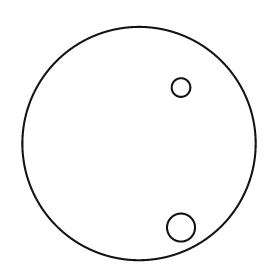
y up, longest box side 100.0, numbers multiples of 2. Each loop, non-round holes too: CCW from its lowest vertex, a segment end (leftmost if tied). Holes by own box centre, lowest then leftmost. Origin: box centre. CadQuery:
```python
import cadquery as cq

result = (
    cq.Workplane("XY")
    .moveTo(0.0, 0.0)
    .circle(50.0)
    .moveTo(18.0, -36.0)
    .circle(6.0)
    .moveTo(18.0, 24.0)
    .circle(4.0)
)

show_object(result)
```